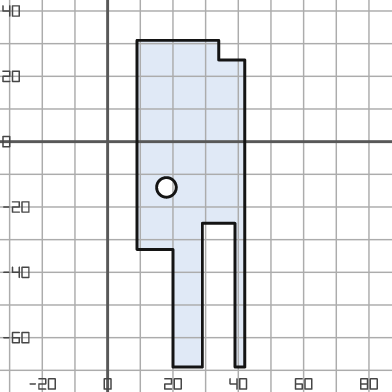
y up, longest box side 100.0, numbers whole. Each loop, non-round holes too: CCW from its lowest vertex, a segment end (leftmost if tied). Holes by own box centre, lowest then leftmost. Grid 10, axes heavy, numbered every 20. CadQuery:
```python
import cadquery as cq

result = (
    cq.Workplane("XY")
    .moveTo(20.0, -69.0)
    .lineTo(29.0, -69.0)
    .lineTo(29.0, -25.0)
    .lineTo(39.0, -25.0)
    .lineTo(39.0, -69.0)
    .lineTo(42.0, -69.0)
    .lineTo(42.0, 25.0)
    .lineTo(34.0, 25.0)
    .lineTo(34.0, 31.0)
    .lineTo(9.0, 31.0)
    .lineTo(9.0, -33.0)
    .lineTo(20.0, -33.0)
    .close()
    .moveTo(18.0, -14.0)
    .circle(3.0)
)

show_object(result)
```